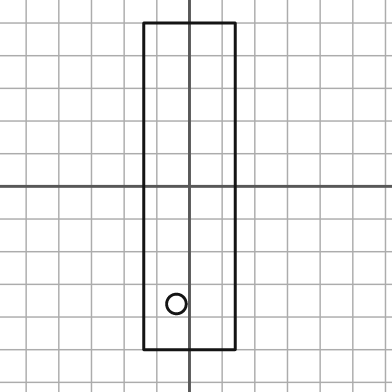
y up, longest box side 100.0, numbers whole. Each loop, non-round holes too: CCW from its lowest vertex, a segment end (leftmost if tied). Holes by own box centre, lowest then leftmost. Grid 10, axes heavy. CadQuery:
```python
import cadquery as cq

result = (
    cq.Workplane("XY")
    .moveTo(-14.0, -50.0)
    .lineTo(14.0, -50.0)
    .lineTo(14.0, 50.0)
    .lineTo(-14.0, 50.0)
    .close()
    .moveTo(-4.0, -36.0)
    .circle(3.0)
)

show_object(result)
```